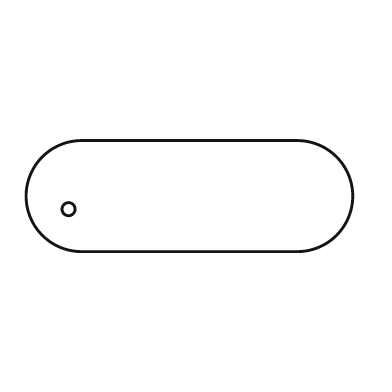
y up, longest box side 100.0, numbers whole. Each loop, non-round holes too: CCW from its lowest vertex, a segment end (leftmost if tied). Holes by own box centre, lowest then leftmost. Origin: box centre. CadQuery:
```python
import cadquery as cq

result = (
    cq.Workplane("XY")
    .moveTo(-33.0, -17.0)
    .lineTo(33.0, -17.0)
    .threePointArc((50.0, 0.0), (33.0, 17.0))
    .lineTo(-33.0, 17.0)
    .threePointArc((-50.0, 0.0), (-33.0, -17.0))
    .close()
    .moveTo(-37.0, -4.0)
    .circle(2.0)
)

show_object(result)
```